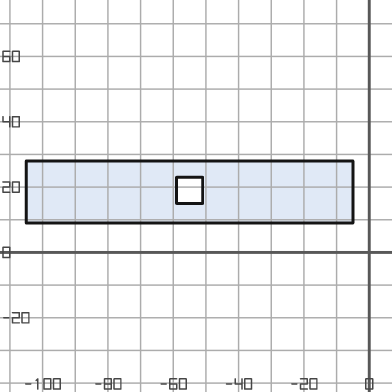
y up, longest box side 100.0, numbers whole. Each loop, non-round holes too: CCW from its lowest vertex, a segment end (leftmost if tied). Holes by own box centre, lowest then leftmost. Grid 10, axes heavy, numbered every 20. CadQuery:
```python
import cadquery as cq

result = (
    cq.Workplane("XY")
    .moveTo(-105.0, 9.0)
    .lineTo(-5.0, 9.0)
    .lineTo(-5.0, 28.0)
    .lineTo(-105.0, 28.0)
    .close()
    .moveTo(-59.0, 15.0)
    .lineTo(-51.0, 15.0)
    .lineTo(-51.0, 23.0)
    .lineTo(-59.0, 23.0)
    .close()
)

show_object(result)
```